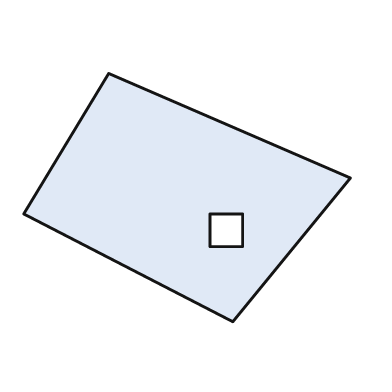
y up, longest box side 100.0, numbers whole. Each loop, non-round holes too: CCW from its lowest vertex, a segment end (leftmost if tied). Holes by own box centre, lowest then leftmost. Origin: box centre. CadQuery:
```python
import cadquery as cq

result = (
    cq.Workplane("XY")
    .moveTo(14.0, -38.0)
    .lineTo(50.0, 6.0)
    .lineTo(-24.0, 38.0)
    .lineTo(-50.0, -5.0)
    .close()
    .moveTo(7.0, -15.0)
    .lineTo(17.0, -15.0)
    .lineTo(17.0, -5.0)
    .lineTo(7.0, -5.0)
    .close()
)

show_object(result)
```